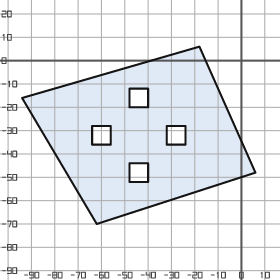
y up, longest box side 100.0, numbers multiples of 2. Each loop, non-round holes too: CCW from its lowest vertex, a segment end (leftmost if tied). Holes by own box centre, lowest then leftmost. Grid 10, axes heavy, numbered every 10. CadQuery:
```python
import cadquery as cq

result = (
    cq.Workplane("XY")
    .moveTo(-62.0, -70.0)
    .lineTo(6.0, -48.0)
    .lineTo(-18.0, 6.0)
    .lineTo(-94.0, -16.0)
    .close()
    .moveTo(-48.0, -52.0)
    .lineTo(-40.0, -52.0)
    .lineTo(-40.0, -44.0)
    .lineTo(-48.0, -44.0)
    .close()
    .moveTo(-64.0, -36.0)
    .lineTo(-56.0, -36.0)
    .lineTo(-56.0, -28.0)
    .lineTo(-64.0, -28.0)
    .close()
    .moveTo(-32.0, -36.0)
    .lineTo(-24.0, -36.0)
    .lineTo(-24.0, -28.0)
    .lineTo(-32.0, -28.0)
    .close()
    .moveTo(-48.0, -20.0)
    .lineTo(-40.0, -20.0)
    .lineTo(-40.0, -12.0)
    .lineTo(-48.0, -12.0)
    .close()
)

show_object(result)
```